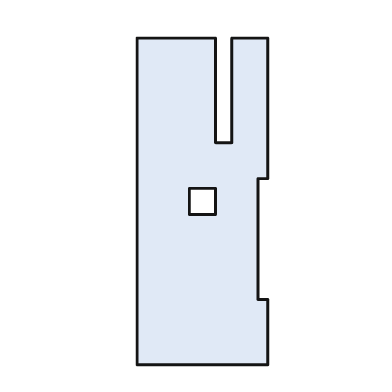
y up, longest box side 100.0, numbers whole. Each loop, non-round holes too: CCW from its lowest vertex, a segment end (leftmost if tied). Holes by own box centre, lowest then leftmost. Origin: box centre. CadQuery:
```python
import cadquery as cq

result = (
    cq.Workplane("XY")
    .moveTo(-20.0, -50.0)
    .lineTo(20.0, -50.0)
    .lineTo(20.0, -30.0)
    .lineTo(17.0, -30.0)
    .lineTo(17.0, 7.0)
    .lineTo(20.0, 7.0)
    .lineTo(20.0, 50.0)
    .lineTo(9.0, 50.0)
    .lineTo(9.0, 18.0)
    .lineTo(4.0, 18.0)
    .lineTo(4.0, 50.0)
    .lineTo(-20.0, 50.0)
    .close()
    .moveTo(-4.0, -4.0)
    .lineTo(4.0, -4.0)
    .lineTo(4.0, 4.0)
    .lineTo(-4.0, 4.0)
    .close()
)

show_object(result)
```